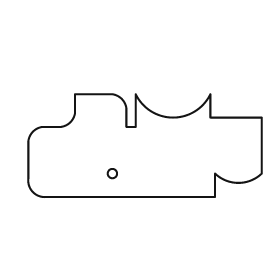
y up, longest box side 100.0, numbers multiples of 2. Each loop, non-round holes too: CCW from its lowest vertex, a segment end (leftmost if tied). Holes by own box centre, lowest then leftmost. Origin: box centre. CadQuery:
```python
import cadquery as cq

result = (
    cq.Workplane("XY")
    .moveTo(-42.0, -22.0)
    .lineTo(30.0, -22.0)
    .lineTo(30.0, -12.0)
    .threePointArc((40.0, -16.0), (50.0, -12.0))
    .lineTo(50.0, 12.0)
    .lineTo(28.0, 12.0)
    .lineTo(28.0, 22.0)
    .threePointArc((12.0, 12.0), (-4.0, 22.0))
    .lineTo(-4.0, 8.0)
    .lineTo(-8.0, 8.0)
    .lineTo(-8.0, 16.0)
    .threePointArc((-10.0, 20.0), (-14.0, 22.0))
    .lineTo(-30.0, 22.0)
    .lineTo(-30.0, 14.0)
    .threePointArc((-32.0, 10.0), (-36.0, 8.0))
    .lineTo(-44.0, 8.0)
    .threePointArc((-48.0, 6.0), (-50.0, 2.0))
    .lineTo(-50.0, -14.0)
    .threePointArc((-48.0, -20.0), (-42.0, -22.0))
    .close()
    .moveTo(-14.0, -12.0)
    .circle(2.0)
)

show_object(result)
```